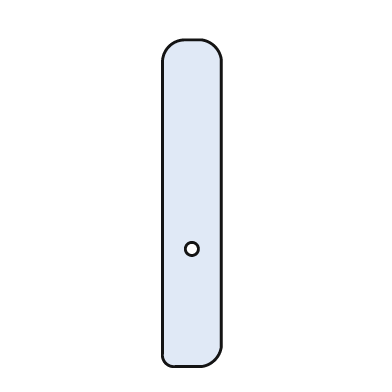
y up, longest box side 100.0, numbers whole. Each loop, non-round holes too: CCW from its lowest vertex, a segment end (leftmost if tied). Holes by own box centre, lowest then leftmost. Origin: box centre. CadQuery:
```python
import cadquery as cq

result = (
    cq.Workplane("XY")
    .moveTo(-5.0, -50.0)
    .lineTo(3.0, -50.0)
    .threePointArc((7.0, -48.0), (9.0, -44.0))
    .lineTo(9.0, 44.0)
    .threePointArc((7.0, 48.0), (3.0, 50.0))
    .lineTo(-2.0, 50.0)
    .threePointArc((-7.0, 48.0), (-9.0, 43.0))
    .lineTo(-9.0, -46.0)
    .threePointArc((-8.0, -49.0), (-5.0, -50.0))
    .close()
    .moveTo(0.0, -14.0)
    .circle(2.0)
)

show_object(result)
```